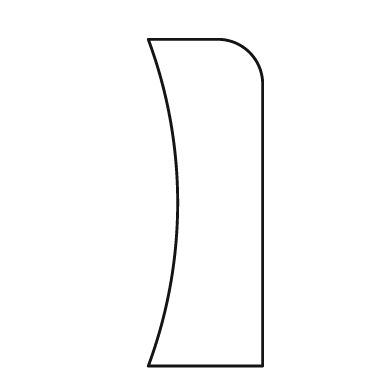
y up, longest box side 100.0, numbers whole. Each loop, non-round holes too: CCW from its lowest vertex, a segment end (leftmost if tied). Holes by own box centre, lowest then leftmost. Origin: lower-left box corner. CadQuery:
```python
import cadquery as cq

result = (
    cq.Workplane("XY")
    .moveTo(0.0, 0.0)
    .lineTo(35.0, 0.0)
    .lineTo(35.0, 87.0)
    .threePointArc((31.0, 96.0), (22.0, 100.0))
    .lineTo(0.0, 100.0)
    .threePointArc((9.0, 50.0), (0.0, 0.0))
    .close()
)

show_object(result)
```